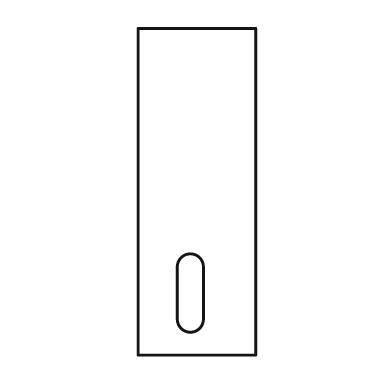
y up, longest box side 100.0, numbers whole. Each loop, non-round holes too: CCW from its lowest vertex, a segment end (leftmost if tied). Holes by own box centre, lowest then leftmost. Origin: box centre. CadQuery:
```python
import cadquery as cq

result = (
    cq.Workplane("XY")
    .moveTo(-18.0, -50.0)
    .lineTo(18.0, -50.0)
    .lineTo(18.0, 50.0)
    .lineTo(-18.0, 50.0)
    .close()
    .moveTo(-6.0, -39.0)
    .threePointArc((-2.0, -43.0), (2.0, -39.0))
    .lineTo(2.0, -23.0)
    .threePointArc((-2.0, -19.0), (-6.0, -23.0))
    .close()
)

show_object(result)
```